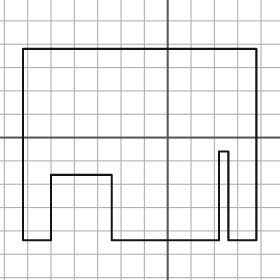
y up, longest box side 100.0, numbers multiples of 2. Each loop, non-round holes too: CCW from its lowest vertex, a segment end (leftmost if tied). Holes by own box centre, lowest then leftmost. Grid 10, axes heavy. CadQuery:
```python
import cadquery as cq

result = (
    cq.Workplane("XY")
    .moveTo(-62.0, -44.0)
    .lineTo(-50.0, -44.0)
    .lineTo(-50.0, -16.0)
    .lineTo(-24.0, -16.0)
    .lineTo(-24.0, -44.0)
    .lineTo(22.0, -44.0)
    .lineTo(22.0, -6.0)
    .lineTo(26.0, -6.0)
    .lineTo(26.0, -44.0)
    .lineTo(38.0, -44.0)
    .lineTo(38.0, 38.0)
    .lineTo(-62.0, 38.0)
    .close()
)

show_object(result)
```